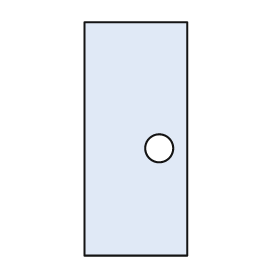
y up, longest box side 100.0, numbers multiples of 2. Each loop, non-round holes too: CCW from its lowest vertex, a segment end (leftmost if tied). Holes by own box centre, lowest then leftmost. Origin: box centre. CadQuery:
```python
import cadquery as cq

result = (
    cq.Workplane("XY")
    .moveTo(-22.0, -50.0)
    .lineTo(22.0, -50.0)
    .lineTo(22.0, 50.0)
    .lineTo(-22.0, 50.0)
    .close()
    .moveTo(10.0, -4.0)
    .circle(6.0)
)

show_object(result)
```